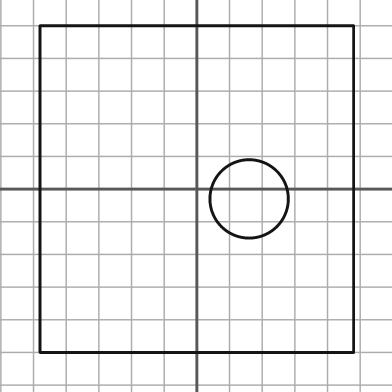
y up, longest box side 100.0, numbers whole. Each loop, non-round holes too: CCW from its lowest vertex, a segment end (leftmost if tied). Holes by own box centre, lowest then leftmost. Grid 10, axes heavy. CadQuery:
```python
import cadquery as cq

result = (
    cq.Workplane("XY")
    .moveTo(-48.0, -50.0)
    .lineTo(48.0, -50.0)
    .lineTo(48.0, 50.0)
    .lineTo(-48.0, 50.0)
    .close()
    .moveTo(16.0, -3.0)
    .circle(12.0)
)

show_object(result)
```